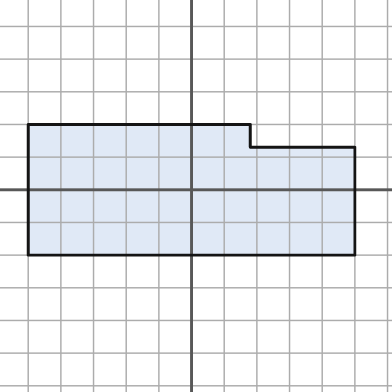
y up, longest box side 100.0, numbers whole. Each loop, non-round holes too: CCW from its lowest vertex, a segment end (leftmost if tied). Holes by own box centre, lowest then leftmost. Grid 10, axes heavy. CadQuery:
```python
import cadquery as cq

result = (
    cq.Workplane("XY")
    .moveTo(-50.0, -20.0)
    .lineTo(50.0, -20.0)
    .lineTo(50.0, 13.0)
    .lineTo(18.0, 13.0)
    .lineTo(18.0, 20.0)
    .lineTo(-50.0, 20.0)
    .close()
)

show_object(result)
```